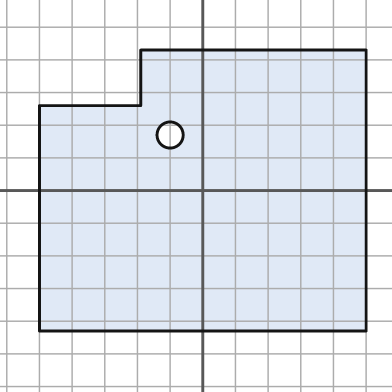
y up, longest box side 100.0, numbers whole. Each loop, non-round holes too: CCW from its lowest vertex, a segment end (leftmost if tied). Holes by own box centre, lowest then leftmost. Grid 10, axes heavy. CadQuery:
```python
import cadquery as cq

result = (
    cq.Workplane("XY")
    .moveTo(-50.0, -43.0)
    .lineTo(50.0, -43.0)
    .lineTo(50.0, 43.0)
    .lineTo(-19.0, 43.0)
    .lineTo(-19.0, 26.0)
    .lineTo(-50.0, 26.0)
    .close()
    .moveTo(-10.0, 17.0)
    .circle(4.0)
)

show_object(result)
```